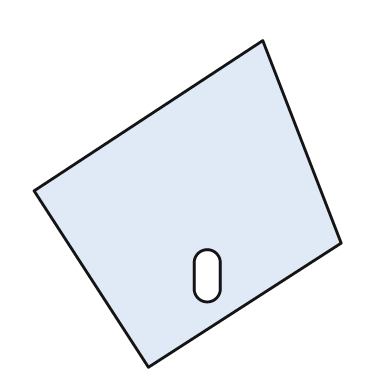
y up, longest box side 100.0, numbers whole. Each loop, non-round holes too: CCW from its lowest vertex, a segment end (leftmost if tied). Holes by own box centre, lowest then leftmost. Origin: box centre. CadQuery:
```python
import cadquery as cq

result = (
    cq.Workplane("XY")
    .moveTo(-12.0, -50.0)
    .lineTo(47.0, -12.0)
    .lineTo(23.0, 50.0)
    .lineTo(-47.0, 4.0)
    .close()
    .moveTo(2.0, -26.0)
    .threePointArc((6.0, -30.0), (10.0, -26.0))
    .lineTo(10.0, -18.0)
    .threePointArc((6.0, -14.0), (2.0, -18.0))
    .close()
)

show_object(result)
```